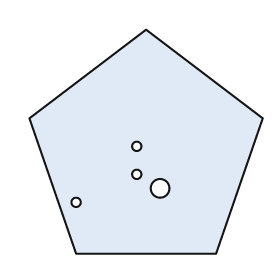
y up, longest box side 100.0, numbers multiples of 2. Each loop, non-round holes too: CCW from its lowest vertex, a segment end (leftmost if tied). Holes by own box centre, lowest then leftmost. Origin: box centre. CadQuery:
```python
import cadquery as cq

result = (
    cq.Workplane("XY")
    .moveTo(-30.0, -48.0)
    .lineTo(30.0, -48.0)
    .lineTo(50.0, 10.0)
    .lineTo(0.0, 48.0)
    .lineTo(-50.0, 10.0)
    .close()
    .moveTo(-30.0, -26.0)
    .circle(2.0)
    .moveTo(6.0, -20.0)
    .circle(4.0)
    .moveTo(-4.0, -14.0)
    .circle(2.0)
    .moveTo(-4.0, -2.0)
    .circle(2.0)
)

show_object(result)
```